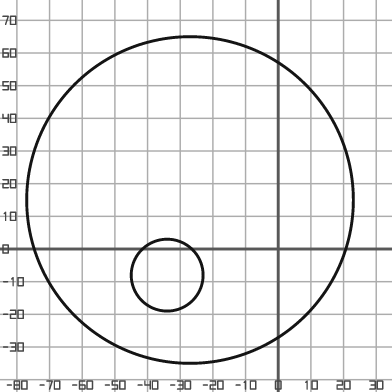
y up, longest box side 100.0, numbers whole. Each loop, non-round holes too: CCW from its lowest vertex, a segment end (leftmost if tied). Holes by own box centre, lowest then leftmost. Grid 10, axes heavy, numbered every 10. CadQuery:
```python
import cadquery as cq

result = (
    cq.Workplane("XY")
    .moveTo(-27.0, 15.0)
    .circle(50.0)
    .moveTo(-34.0, -8.0)
    .circle(11.0)
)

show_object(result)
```